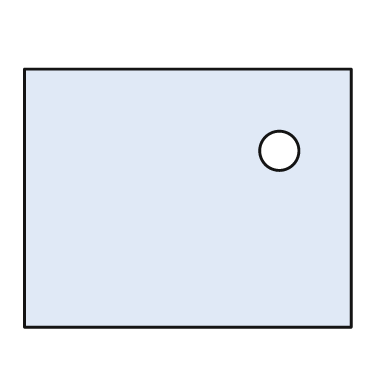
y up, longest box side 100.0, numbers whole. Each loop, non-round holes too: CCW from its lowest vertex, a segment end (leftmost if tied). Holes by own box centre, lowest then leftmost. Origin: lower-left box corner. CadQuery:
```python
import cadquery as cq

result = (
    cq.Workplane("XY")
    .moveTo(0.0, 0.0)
    .lineTo(100.0, 0.0)
    .lineTo(100.0, 79.0)
    .lineTo(0.0, 79.0)
    .close()
    .moveTo(78.0, 54.0)
    .circle(6.0)
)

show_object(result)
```